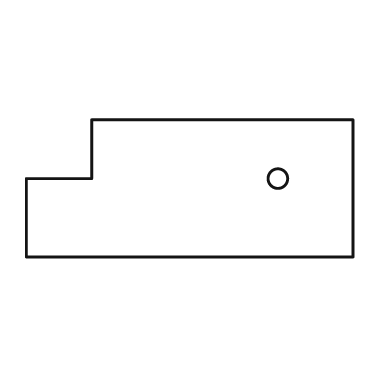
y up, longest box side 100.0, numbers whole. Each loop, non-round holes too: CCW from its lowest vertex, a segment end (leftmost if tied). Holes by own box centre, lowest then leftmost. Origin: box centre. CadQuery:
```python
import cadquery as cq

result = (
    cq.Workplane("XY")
    .moveTo(-50.0, -21.0)
    .lineTo(50.0, -21.0)
    .lineTo(50.0, 21.0)
    .lineTo(-30.0, 21.0)
    .lineTo(-30.0, 3.0)
    .lineTo(-50.0, 3.0)
    .close()
    .moveTo(27.0, 3.0)
    .circle(3.0)
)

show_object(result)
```